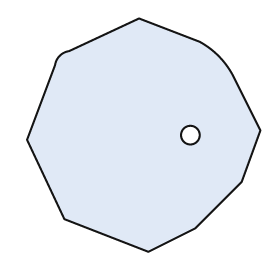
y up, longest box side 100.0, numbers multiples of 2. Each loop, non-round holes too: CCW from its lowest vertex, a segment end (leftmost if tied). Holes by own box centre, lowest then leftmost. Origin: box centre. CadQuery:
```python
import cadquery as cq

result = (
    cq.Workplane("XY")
    .moveTo(2.0, -50.0)
    .lineTo(22.0, -40.0)
    .lineTo(42.0, -20.0)
    .lineTo(50.0, 2.0)
    .lineTo(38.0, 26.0)
    .threePointArc((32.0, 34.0), (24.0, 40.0))
    .lineTo(-2.0, 50.0)
    .lineTo(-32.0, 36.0)
    .threePointArc((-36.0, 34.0), (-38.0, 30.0))
    .lineTo(-50.0, -2.0)
    .lineTo(-34.0, -36.0)
    .close()
    .moveTo(20.0, 0.0)
    .circle(4.0)
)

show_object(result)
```